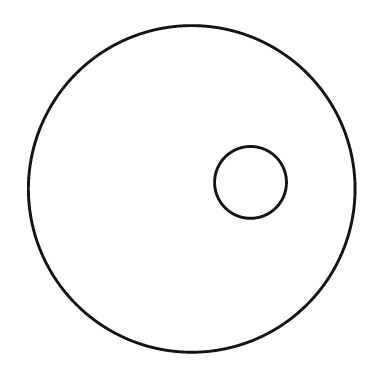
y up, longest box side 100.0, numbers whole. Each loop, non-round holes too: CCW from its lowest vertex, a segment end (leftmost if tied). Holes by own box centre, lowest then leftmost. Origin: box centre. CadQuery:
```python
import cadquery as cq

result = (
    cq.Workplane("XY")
    .moveTo(0.0, 0.0)
    .circle(50.0)
    .moveTo(18.0, 2.0)
    .circle(11.0)
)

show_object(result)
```